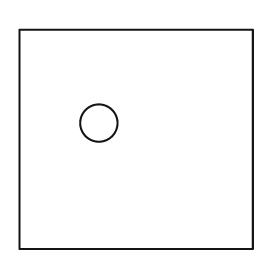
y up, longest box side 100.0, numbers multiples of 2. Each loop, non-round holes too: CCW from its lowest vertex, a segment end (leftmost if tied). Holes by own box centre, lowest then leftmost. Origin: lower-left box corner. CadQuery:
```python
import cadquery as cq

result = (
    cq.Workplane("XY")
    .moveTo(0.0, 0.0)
    .lineTo(100.0, 0.0)
    .lineTo(100.0, 94.0)
    .lineTo(0.0, 94.0)
    .close()
    .moveTo(34.0, 54.0)
    .circle(8.0)
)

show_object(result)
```